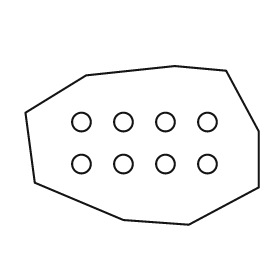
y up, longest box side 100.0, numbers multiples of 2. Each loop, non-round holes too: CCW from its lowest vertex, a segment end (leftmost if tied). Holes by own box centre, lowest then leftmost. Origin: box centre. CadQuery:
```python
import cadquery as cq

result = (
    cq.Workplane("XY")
    .moveTo(20.0, -34.0)
    .lineTo(50.0, -18.0)
    .lineTo(50.0, 6.0)
    .lineTo(36.0, 32.0)
    .lineTo(14.0, 34.0)
    .lineTo(-24.0, 30.0)
    .lineTo(-50.0, 14.0)
    .lineTo(-46.0, -16.0)
    .lineTo(-8.0, -32.0)
    .close()
    .moveTo(-26.0, -8.0)
    .circle(4.0)
    .moveTo(-8.0, -8.0)
    .circle(4.0)
    .moveTo(10.0, -8.0)
    .circle(4.0)
    .moveTo(28.0, -8.0)
    .circle(4.0)
    .moveTo(-26.0, 10.0)
    .circle(4.0)
    .moveTo(-8.0, 10.0)
    .circle(4.0)
    .moveTo(10.0, 10.0)
    .circle(4.0)
    .moveTo(28.0, 10.0)
    .circle(4.0)
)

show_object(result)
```